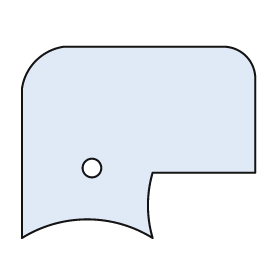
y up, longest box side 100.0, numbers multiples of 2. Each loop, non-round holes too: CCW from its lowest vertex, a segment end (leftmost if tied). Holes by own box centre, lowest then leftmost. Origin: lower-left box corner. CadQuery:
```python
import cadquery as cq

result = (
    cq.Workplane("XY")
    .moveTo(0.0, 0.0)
    .threePointArc((28.0, 8.0), (56.0, 0.0))
    .threePointArc((54.0, 14.0), (56.0, 28.0))
    .lineTo(100.0, 28.0)
    .lineTo(100.0, 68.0)
    .threePointArc((96.0, 78.0), (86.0, 82.0))
    .lineTo(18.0, 82.0)
    .threePointArc((6.0, 76.0), (0.0, 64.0))
    .close()
    .moveTo(30.0, 30.0)
    .circle(4.0)
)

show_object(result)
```